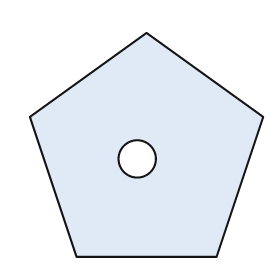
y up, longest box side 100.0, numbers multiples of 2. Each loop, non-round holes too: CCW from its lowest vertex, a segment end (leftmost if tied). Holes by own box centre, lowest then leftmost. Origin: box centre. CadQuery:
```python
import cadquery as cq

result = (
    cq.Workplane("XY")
    .moveTo(-30.0, -48.0)
    .lineTo(30.0, -48.0)
    .lineTo(50.0, 12.0)
    .lineTo(0.0, 48.0)
    .lineTo(-50.0, 12.0)
    .close()
    .moveTo(-4.0, -6.0)
    .circle(8.0)
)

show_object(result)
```